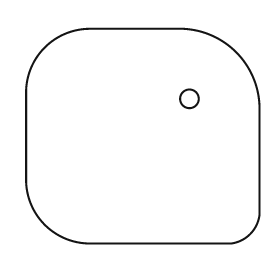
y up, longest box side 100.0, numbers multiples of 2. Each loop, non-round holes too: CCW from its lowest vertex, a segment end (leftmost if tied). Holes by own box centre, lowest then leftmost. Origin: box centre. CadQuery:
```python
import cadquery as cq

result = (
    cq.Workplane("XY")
    .moveTo(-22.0, -46.0)
    .lineTo(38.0, -46.0)
    .threePointArc((46.0, -42.0), (50.0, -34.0))
    .lineTo(50.0, 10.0)
    .threePointArc((40.0, 36.0), (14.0, 46.0))
    .lineTo(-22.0, 46.0)
    .threePointArc((-42.0, 38.0), (-50.0, 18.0))
    .lineTo(-50.0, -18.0)
    .threePointArc((-42.0, -38.0), (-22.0, -46.0))
    .close()
    .moveTo(20.0, 16.0)
    .circle(4.0)
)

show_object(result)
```